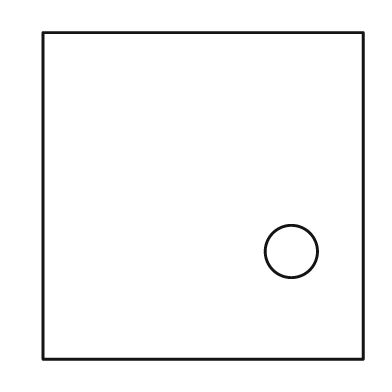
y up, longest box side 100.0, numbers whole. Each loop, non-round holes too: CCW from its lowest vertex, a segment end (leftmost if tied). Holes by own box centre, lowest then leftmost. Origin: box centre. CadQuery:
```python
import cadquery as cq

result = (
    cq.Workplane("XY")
    .moveTo(-49.0, -50.0)
    .lineTo(49.0, -50.0)
    .lineTo(49.0, 50.0)
    .lineTo(-49.0, 50.0)
    .close()
    .moveTo(27.0, -17.0)
    .circle(8.0)
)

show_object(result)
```